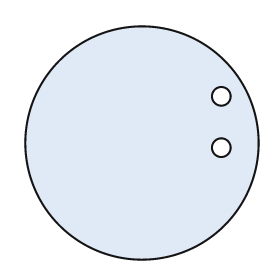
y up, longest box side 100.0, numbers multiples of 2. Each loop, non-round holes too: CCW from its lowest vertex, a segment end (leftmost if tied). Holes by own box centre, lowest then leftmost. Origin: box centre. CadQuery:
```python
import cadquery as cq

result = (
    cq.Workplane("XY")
    .moveTo(0.0, 0.0)
    .circle(50.0)
    .moveTo(34.0, -2.0)
    .circle(4.0)
    .moveTo(34.0, 20.0)
    .circle(4.0)
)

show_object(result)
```